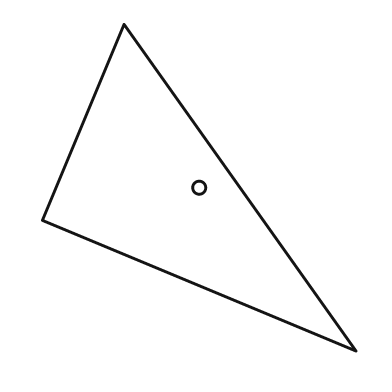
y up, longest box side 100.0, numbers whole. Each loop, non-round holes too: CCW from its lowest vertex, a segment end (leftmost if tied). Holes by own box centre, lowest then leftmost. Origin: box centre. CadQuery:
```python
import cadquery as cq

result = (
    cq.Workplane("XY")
    .moveTo(48.0, -50.0)
    .lineTo(-23.0, 50.0)
    .lineTo(-48.0, -10.0)
    .close()
    .moveTo(0.0, 0.0)
    .circle(2.0)
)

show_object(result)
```